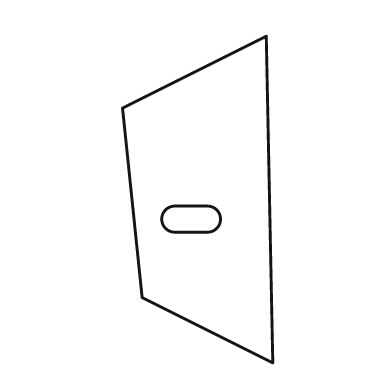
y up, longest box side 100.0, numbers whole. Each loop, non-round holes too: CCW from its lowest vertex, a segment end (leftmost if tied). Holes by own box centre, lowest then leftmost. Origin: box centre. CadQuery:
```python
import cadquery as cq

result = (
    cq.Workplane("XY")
    .moveTo(23.0, -50.0)
    .lineTo(21.0, 50.0)
    .lineTo(-23.0, 28.0)
    .lineTo(-17.0, -30.0)
    .close()
    .moveTo(-7.0, -10.0)
    .lineTo(3.0, -10.0)
    .threePointArc((7.0, -6.0), (3.0, -2.0))
    .lineTo(-7.0, -2.0)
    .threePointArc((-11.0, -6.0), (-7.0, -10.0))
    .close()
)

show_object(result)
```